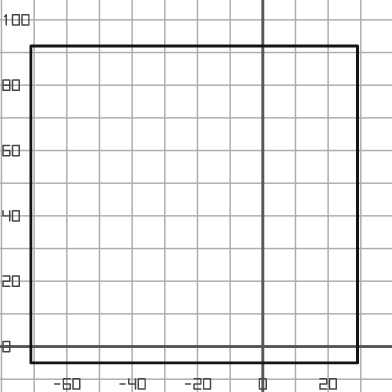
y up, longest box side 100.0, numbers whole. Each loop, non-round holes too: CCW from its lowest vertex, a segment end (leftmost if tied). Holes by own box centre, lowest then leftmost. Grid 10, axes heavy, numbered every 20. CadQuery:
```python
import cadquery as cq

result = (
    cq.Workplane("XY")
    .moveTo(-71.0, -5.0)
    .lineTo(29.0, -5.0)
    .lineTo(29.0, 92.0)
    .lineTo(-71.0, 92.0)
    .close()
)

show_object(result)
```